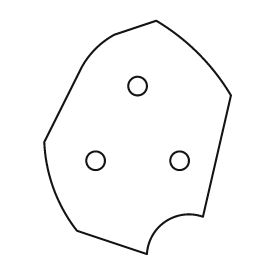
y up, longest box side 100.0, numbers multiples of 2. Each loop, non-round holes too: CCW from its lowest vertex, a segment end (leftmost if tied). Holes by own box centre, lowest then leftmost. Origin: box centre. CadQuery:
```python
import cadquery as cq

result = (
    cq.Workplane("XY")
    .moveTo(4.0, -50.0)
    .threePointArc((12.0, -36.0), (28.0, -34.0))
    .lineTo(40.0, 18.0)
    .threePointArc((26.0, 36.0), (8.0, 50.0))
    .lineTo(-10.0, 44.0)
    .threePointArc((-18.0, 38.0), (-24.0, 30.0))
    .lineTo(-40.0, -2.0)
    .threePointArc((-36.0, -22.0), (-26.0, -40.0))
    .close()
    .moveTo(-18.0, -10.0)
    .circle(4.0)
    .moveTo(18.0, -10.0)
    .circle(4.0)
    .moveTo(0.0, 22.0)
    .circle(4.0)
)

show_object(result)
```